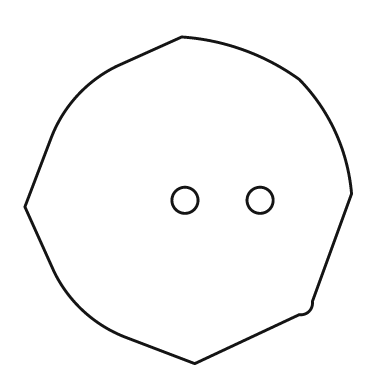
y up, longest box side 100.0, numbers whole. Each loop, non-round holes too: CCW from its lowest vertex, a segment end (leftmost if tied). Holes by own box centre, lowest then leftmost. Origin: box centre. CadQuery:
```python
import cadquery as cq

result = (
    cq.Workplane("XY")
    .moveTo(2.0, -50.0)
    .lineTo(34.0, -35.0)
    .threePointArc((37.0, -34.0), (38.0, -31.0))
    .lineTo(50.0, 2.0)
    .threePointArc((45.0, 21.0), (34.0, 37.0))
    .threePointArc((17.0, 46.0), (-2.0, 50.0))
    .lineTo(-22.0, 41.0)
    .threePointArc((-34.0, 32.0), (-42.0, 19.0))
    .lineTo(-50.0, -2.0)
    .lineTo(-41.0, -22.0)
    .threePointArc((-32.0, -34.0), (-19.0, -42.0))
    .close()
    .moveTo(-1.0, 0.0)
    .circle(4.0)
    .moveTo(22.0, 0.0)
    .circle(4.0)
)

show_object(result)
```